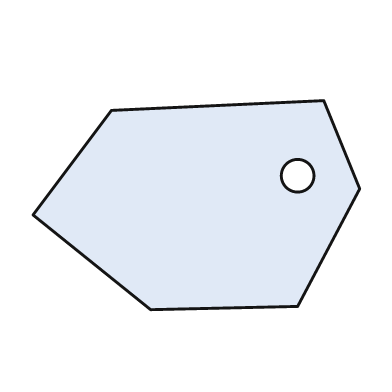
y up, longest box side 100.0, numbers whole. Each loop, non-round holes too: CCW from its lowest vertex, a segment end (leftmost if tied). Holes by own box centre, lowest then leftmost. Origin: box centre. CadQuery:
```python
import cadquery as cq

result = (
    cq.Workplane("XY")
    .moveTo(-14.0, -32.0)
    .lineTo(31.0, -31.0)
    .lineTo(50.0, 5.0)
    .lineTo(39.0, 32.0)
    .lineTo(-26.0, 29.0)
    .lineTo(-50.0, -3.0)
    .close()
    .moveTo(31.0, 9.0)
    .circle(5.0)
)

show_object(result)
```